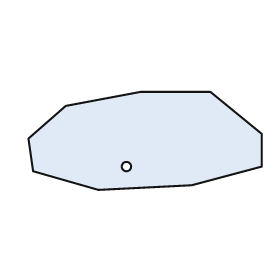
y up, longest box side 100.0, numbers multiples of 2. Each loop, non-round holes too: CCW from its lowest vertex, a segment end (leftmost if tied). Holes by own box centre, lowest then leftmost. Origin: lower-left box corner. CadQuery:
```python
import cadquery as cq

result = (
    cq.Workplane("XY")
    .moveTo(30.0, 0.0)
    .lineTo(70.0, 2.0)
    .lineTo(100.0, 10.0)
    .lineTo(100.0, 24.0)
    .lineTo(78.0, 42.0)
    .lineTo(48.0, 42.0)
    .lineTo(16.0, 36.0)
    .lineTo(0.0, 22.0)
    .lineTo(2.0, 8.0)
    .close()
    .moveTo(42.0, 10.0)
    .circle(2.0)
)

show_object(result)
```